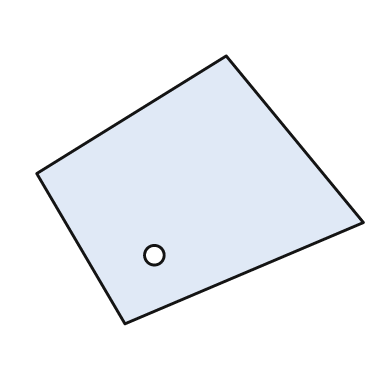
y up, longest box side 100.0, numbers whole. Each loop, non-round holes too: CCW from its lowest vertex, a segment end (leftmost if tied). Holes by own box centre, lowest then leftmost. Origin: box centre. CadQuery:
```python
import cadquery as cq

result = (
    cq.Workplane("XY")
    .moveTo(-23.0, -41.0)
    .lineTo(50.0, -10.0)
    .lineTo(8.0, 41.0)
    .lineTo(-50.0, 5.0)
    .close()
    .moveTo(-14.0, -20.0)
    .circle(3.0)
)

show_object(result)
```